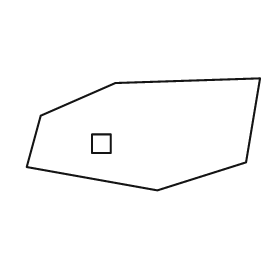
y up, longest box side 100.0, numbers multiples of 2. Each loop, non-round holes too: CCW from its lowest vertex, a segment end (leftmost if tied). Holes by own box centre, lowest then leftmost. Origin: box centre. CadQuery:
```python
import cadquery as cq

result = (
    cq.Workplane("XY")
    .moveTo(6.0, -24.0)
    .lineTo(44.0, -12.0)
    .lineTo(50.0, 24.0)
    .lineTo(-12.0, 22.0)
    .lineTo(-44.0, 8.0)
    .lineTo(-50.0, -14.0)
    .close()
    .moveTo(-22.0, -8.0)
    .lineTo(-14.0, -8.0)
    .lineTo(-14.0, 0.0)
    .lineTo(-22.0, 0.0)
    .close()
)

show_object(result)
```